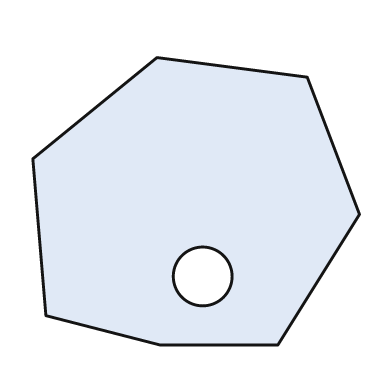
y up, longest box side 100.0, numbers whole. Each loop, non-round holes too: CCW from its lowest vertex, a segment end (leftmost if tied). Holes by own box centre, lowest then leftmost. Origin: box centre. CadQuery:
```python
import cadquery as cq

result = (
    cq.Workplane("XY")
    .moveTo(-11.0, -44.0)
    .lineTo(25.0, -44.0)
    .lineTo(50.0, -4.0)
    .lineTo(34.0, 38.0)
    .lineTo(-12.0, 44.0)
    .lineTo(-50.0, 13.0)
    .lineTo(-46.0, -35.0)
    .close()
    .moveTo(2.0, -23.0)
    .circle(9.0)
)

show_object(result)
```